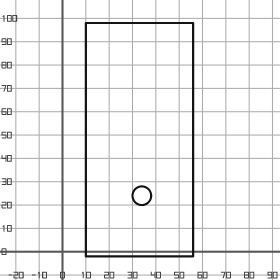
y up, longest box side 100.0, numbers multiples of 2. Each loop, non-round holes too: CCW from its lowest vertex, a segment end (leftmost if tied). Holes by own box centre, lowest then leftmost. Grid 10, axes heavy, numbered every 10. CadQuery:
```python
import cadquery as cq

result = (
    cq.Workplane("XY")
    .moveTo(10.0, -2.0)
    .lineTo(56.0, -2.0)
    .lineTo(56.0, 98.0)
    .lineTo(10.0, 98.0)
    .close()
    .moveTo(34.0, 24.0)
    .circle(4.0)
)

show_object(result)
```